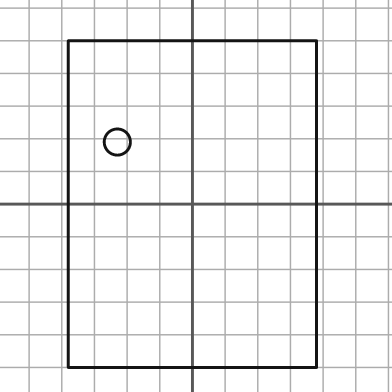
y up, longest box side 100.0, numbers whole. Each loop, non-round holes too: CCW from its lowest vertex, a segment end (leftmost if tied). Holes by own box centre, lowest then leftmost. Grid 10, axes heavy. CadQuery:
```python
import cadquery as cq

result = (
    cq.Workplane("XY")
    .moveTo(-38.0, -50.0)
    .lineTo(38.0, -50.0)
    .lineTo(38.0, 50.0)
    .lineTo(-38.0, 50.0)
    .close()
    .moveTo(-23.0, 19.0)
    .circle(4.0)
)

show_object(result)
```